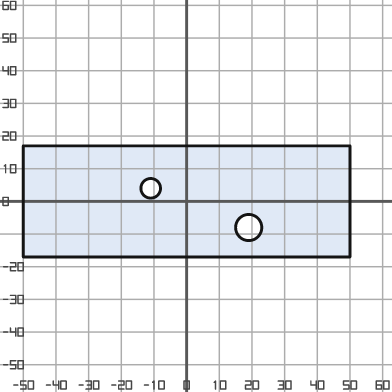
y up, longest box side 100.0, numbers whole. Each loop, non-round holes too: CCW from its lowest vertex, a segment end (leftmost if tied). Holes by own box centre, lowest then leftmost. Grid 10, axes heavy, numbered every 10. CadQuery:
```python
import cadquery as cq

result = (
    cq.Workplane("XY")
    .moveTo(-50.0, -17.0)
    .lineTo(50.0, -17.0)
    .lineTo(50.0, 17.0)
    .lineTo(-50.0, 17.0)
    .close()
    .moveTo(19.0, -8.0)
    .circle(4.0)
    .moveTo(-11.0, 4.0)
    .circle(3.0)
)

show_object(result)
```